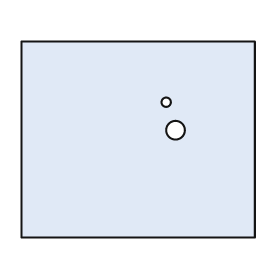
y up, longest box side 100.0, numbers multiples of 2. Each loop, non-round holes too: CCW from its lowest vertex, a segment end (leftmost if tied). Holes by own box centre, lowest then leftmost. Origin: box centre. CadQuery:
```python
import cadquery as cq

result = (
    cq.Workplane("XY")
    .moveTo(-50.0, -42.0)
    .lineTo(50.0, -42.0)
    .lineTo(50.0, 42.0)
    .lineTo(-50.0, 42.0)
    .close()
    .moveTo(16.0, 4.0)
    .circle(4.0)
    .moveTo(12.0, 16.0)
    .circle(2.0)
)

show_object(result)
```